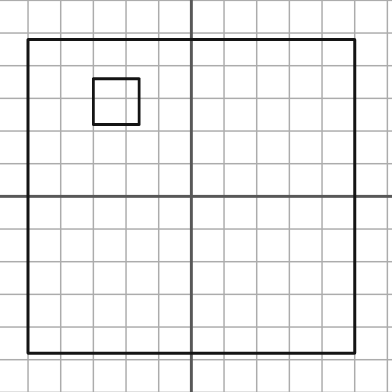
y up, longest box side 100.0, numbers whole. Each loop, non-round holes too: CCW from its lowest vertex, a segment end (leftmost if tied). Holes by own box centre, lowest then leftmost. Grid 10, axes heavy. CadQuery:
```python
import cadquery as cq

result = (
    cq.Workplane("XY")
    .moveTo(-50.0, -48.0)
    .lineTo(50.0, -48.0)
    .lineTo(50.0, 48.0)
    .lineTo(-50.0, 48.0)
    .close()
    .moveTo(-30.0, 22.0)
    .lineTo(-16.0, 22.0)
    .lineTo(-16.0, 36.0)
    .lineTo(-30.0, 36.0)
    .close()
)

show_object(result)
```